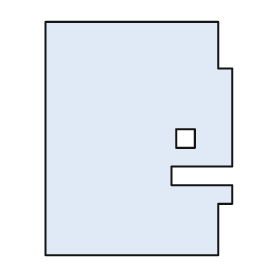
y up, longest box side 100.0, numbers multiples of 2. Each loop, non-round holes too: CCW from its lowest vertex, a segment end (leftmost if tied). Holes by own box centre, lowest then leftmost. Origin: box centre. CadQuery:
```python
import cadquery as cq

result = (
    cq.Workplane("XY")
    .moveTo(-40.0, -50.0)
    .lineTo(34.0, -50.0)
    .lineTo(34.0, -28.0)
    .lineTo(40.0, -28.0)
    .lineTo(40.0, -20.0)
    .lineTo(14.0, -20.0)
    .lineTo(14.0, -12.0)
    .lineTo(40.0, -12.0)
    .lineTo(40.0, 30.0)
    .lineTo(34.0, 30.0)
    .lineTo(34.0, 50.0)
    .lineTo(-40.0, 50.0)
    .close()
    .moveTo(16.0, -4.0)
    .lineTo(24.0, -4.0)
    .lineTo(24.0, 4.0)
    .lineTo(16.0, 4.0)
    .close()
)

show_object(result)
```